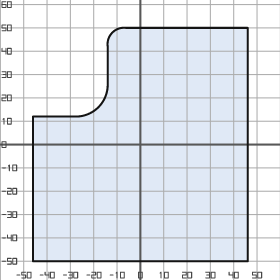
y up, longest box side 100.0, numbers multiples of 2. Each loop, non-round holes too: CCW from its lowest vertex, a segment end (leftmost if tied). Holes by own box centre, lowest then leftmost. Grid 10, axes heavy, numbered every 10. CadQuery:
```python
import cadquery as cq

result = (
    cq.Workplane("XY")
    .moveTo(-46.0, -50.0)
    .lineTo(46.0, -50.0)
    .lineTo(46.0, 50.0)
    .lineTo(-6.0, 50.0)
    .threePointArc((-12.0, 48.0), (-14.0, 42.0))
    .lineTo(-14.0, 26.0)
    .threePointArc((-18.0, 16.0), (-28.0, 12.0))
    .lineTo(-46.0, 12.0)
    .close()
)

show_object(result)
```